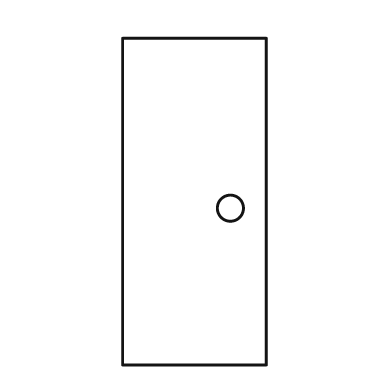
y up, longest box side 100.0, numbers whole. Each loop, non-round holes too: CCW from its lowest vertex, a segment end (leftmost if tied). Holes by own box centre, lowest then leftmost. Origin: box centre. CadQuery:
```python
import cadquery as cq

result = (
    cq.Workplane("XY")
    .moveTo(-22.0, -50.0)
    .lineTo(22.0, -50.0)
    .lineTo(22.0, 50.0)
    .lineTo(-22.0, 50.0)
    .close()
    .moveTo(11.0, -2.0)
    .circle(4.0)
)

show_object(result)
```